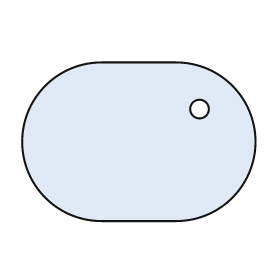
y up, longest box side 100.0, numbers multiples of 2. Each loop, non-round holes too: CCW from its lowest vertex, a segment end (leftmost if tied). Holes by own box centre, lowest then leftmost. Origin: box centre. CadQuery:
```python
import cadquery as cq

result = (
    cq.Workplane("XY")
    .moveTo(-16.0, -34.0)
    .lineTo(16.0, -34.0)
    .threePointArc((50.0, 0.0), (16.0, 34.0))
    .lineTo(-16.0, 34.0)
    .threePointArc((-50.0, 0.0), (-16.0, -34.0))
    .close()
    .moveTo(26.0, 14.0)
    .circle(4.0)
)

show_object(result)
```